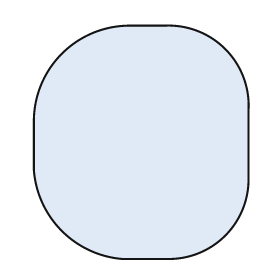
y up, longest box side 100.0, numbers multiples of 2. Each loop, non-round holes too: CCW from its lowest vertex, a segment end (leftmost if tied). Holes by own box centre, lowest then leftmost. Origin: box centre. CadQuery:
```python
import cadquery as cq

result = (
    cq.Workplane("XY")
    .moveTo(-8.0, -50.0)
    .lineTo(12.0, -50.0)
    .threePointArc((36.0, -40.0), (46.0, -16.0))
    .lineTo(46.0, 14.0)
    .threePointArc((36.0, 40.0), (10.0, 50.0))
    .lineTo(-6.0, 50.0)
    .threePointArc((-34.0, 38.0), (-46.0, 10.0))
    .lineTo(-46.0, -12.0)
    .threePointArc((-34.0, -38.0), (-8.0, -50.0))
    .close()
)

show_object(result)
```